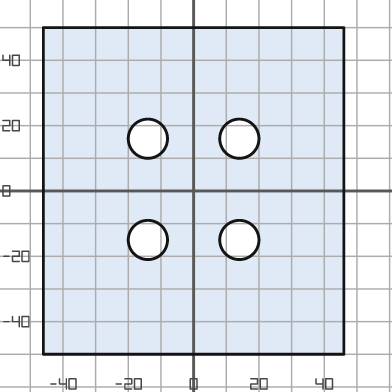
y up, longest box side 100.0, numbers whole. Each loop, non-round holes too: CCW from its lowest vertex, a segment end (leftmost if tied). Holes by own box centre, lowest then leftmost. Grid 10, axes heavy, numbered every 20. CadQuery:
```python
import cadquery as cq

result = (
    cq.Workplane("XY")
    .moveTo(-46.0, -50.0)
    .lineTo(46.0, -50.0)
    .lineTo(46.0, 50.0)
    .lineTo(-46.0, 50.0)
    .close()
    .moveTo(-14.0, -15.0)
    .circle(6.0)
    .moveTo(14.0, -15.0)
    .circle(6.0)
    .moveTo(-14.0, 16.0)
    .circle(6.0)
    .moveTo(14.0, 16.0)
    .circle(6.0)
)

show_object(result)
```